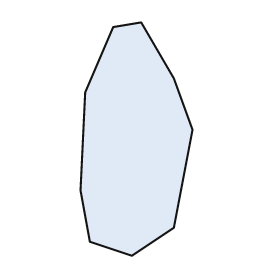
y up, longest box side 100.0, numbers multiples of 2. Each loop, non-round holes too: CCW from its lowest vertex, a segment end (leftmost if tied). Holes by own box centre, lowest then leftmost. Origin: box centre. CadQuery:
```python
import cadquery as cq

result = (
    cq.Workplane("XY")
    .moveTo(-2.0, -50.0)
    .lineTo(16.0, -38.0)
    .lineTo(24.0, 4.0)
    .lineTo(16.0, 26.0)
    .lineTo(2.0, 50.0)
    .lineTo(-10.0, 48.0)
    .lineTo(-22.0, 20.0)
    .lineTo(-24.0, -22.0)
    .lineTo(-20.0, -44.0)
    .close()
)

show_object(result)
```